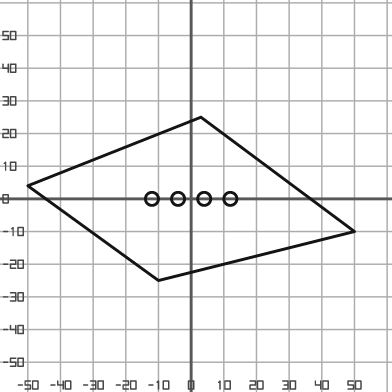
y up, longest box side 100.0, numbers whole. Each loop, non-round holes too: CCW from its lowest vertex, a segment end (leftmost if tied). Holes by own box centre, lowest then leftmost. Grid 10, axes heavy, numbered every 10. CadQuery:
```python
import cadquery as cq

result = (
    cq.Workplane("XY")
    .moveTo(-10.0, -25.0)
    .lineTo(50.0, -10.0)
    .lineTo(3.0, 25.0)
    .lineTo(-50.0, 4.0)
    .close()
    .moveTo(-12.0, 0.0)
    .circle(2.0)
    .moveTo(-4.0, 0.0)
    .circle(2.0)
    .moveTo(4.0, 0.0)
    .circle(2.0)
    .moveTo(12.0, 0.0)
    .circle(2.0)
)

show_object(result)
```